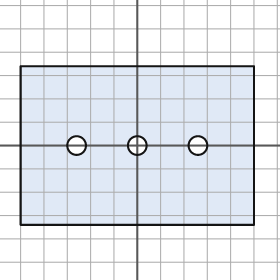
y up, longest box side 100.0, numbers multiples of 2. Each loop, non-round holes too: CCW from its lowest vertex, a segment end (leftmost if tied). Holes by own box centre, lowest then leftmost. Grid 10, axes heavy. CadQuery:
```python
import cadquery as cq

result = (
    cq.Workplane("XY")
    .moveTo(-50.0, -34.0)
    .lineTo(50.0, -34.0)
    .lineTo(50.0, 34.0)
    .lineTo(-50.0, 34.0)
    .close()
    .moveTo(-26.0, 0.0)
    .circle(4.0)
    .moveTo(0.0, 0.0)
    .circle(4.0)
    .moveTo(26.0, 0.0)
    .circle(4.0)
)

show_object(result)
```